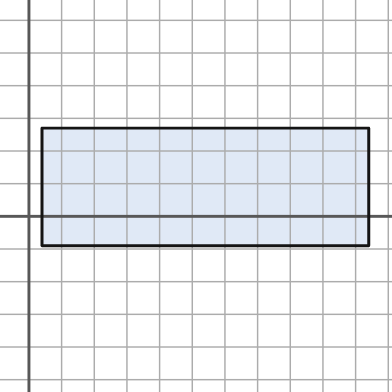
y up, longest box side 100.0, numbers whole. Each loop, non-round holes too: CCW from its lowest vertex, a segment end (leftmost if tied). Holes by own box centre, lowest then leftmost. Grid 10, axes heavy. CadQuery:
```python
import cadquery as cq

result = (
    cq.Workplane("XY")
    .moveTo(4.0, -9.0)
    .lineTo(104.0, -9.0)
    .lineTo(104.0, 27.0)
    .lineTo(4.0, 27.0)
    .close()
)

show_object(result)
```